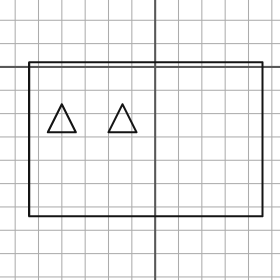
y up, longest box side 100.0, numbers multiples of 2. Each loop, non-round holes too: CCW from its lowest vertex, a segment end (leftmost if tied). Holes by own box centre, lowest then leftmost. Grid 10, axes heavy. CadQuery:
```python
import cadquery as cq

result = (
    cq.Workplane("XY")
    .moveTo(-54.0, -64.0)
    .lineTo(46.0, -64.0)
    .lineTo(46.0, 2.0)
    .lineTo(-54.0, 2.0)
    .close()
    .moveTo(-46.0, -28.0)
    .lineTo(-34.0, -28.0)
    .lineTo(-40.0, -16.0)
    .close()
    .moveTo(-20.0, -28.0)
    .lineTo(-8.0, -28.0)
    .lineTo(-14.0, -16.0)
    .close()
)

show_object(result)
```